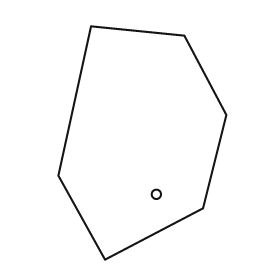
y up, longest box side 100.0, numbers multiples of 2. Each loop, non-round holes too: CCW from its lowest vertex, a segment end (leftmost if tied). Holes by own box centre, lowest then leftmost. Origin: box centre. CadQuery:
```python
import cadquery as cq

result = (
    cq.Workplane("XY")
    .moveTo(-16.0, -50.0)
    .lineTo(26.0, -28.0)
    .lineTo(36.0, 12.0)
    .lineTo(18.0, 46.0)
    .lineTo(-22.0, 50.0)
    .lineTo(-36.0, -14.0)
    .close()
    .moveTo(6.0, -22.0)
    .circle(2.0)
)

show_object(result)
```